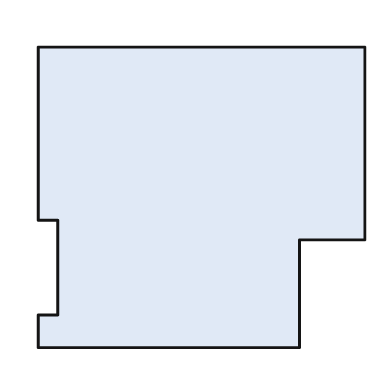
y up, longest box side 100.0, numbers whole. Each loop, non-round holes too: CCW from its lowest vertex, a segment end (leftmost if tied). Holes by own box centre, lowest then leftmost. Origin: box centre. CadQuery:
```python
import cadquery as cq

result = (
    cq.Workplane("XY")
    .moveTo(-50.0, -46.0)
    .lineTo(30.0, -46.0)
    .lineTo(30.0, -13.0)
    .lineTo(50.0, -13.0)
    .lineTo(50.0, 46.0)
    .lineTo(-50.0, 46.0)
    .lineTo(-50.0, -7.0)
    .lineTo(-44.0, -7.0)
    .lineTo(-44.0, -36.0)
    .lineTo(-50.0, -36.0)
    .close()
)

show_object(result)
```